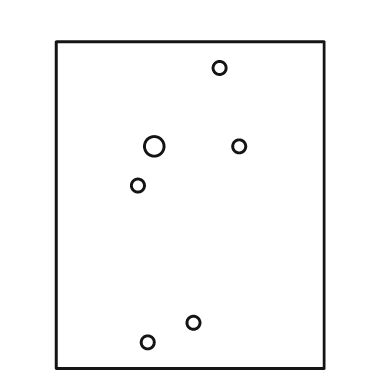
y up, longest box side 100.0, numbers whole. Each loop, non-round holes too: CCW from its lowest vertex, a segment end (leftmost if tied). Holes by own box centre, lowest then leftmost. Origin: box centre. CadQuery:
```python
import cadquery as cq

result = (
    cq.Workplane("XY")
    .moveTo(-41.0, -50.0)
    .lineTo(41.0, -50.0)
    .lineTo(41.0, 50.0)
    .lineTo(-41.0, 50.0)
    .close()
    .moveTo(-13.0, -42.0)
    .circle(2.0)
    .moveTo(1.0, -36.0)
    .circle(2.0)
    .moveTo(-16.0, 6.0)
    .circle(2.0)
    .moveTo(-11.0, 18.0)
    .circle(3.0)
    .moveTo(15.0, 18.0)
    .circle(2.0)
    .moveTo(9.0, 42.0)
    .circle(2.0)
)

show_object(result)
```